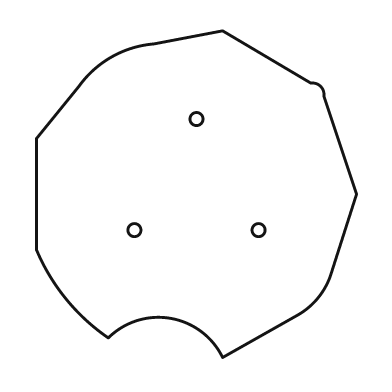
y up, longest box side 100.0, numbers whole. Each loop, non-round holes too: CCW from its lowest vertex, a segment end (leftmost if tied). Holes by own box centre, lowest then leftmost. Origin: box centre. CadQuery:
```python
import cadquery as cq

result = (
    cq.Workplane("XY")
    .moveTo(8.0, -50.0)
    .lineTo(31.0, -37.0)
    .threePointArc((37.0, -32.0), (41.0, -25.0))
    .lineTo(49.0, 0.0)
    .lineTo(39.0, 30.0)
    .threePointArc((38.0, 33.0), (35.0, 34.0))
    .lineTo(8.0, 50.0)
    .lineTo(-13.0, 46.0)
    .threePointArc((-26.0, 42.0), (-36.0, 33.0))
    .lineTo(-49.0, 17.0)
    .lineTo(-49.0, -17.0)
    .threePointArc((-40.0, -32.0), (-27.0, -44.0))
    .threePointArc((-8.0, -38.0), (8.0, -50.0))
    .close()
    .moveTo(-19.0, -11.0)
    .circle(2.0)
    .moveTo(19.0, -11.0)
    .circle(2.0)
    .moveTo(0.0, 23.0)
    .circle(2.0)
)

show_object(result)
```